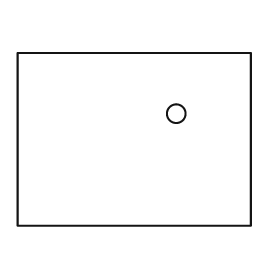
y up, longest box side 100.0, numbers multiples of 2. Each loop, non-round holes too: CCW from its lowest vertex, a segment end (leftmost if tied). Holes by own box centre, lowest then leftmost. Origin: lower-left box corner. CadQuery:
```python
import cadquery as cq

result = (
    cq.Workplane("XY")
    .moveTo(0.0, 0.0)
    .lineTo(100.0, 0.0)
    .lineTo(100.0, 74.0)
    .lineTo(0.0, 74.0)
    .close()
    .moveTo(68.0, 48.0)
    .circle(4.0)
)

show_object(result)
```